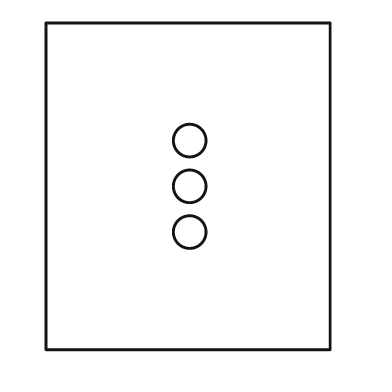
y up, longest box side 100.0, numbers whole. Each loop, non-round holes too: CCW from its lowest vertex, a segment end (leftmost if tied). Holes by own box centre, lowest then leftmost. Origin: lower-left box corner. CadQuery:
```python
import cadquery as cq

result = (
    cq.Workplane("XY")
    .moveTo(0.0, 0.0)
    .lineTo(87.0, 0.0)
    .lineTo(87.0, 100.0)
    .lineTo(0.0, 100.0)
    .close()
    .moveTo(44.0, 36.0)
    .circle(5.0)
    .moveTo(44.0, 50.0)
    .circle(5.0)
    .moveTo(44.0, 64.0)
    .circle(5.0)
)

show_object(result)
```